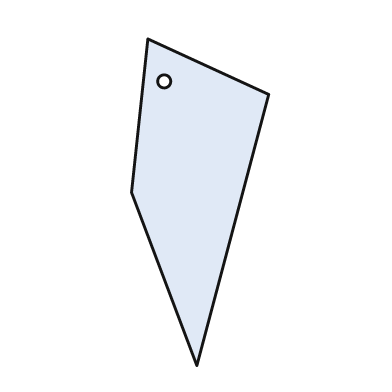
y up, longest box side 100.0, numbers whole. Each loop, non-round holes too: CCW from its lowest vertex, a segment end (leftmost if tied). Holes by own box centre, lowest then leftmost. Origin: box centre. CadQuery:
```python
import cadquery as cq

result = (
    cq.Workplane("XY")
    .moveTo(-1.0, -50.0)
    .lineTo(21.0, 33.0)
    .lineTo(-16.0, 50.0)
    .lineTo(-21.0, 3.0)
    .close()
    .moveTo(-11.0, 37.0)
    .circle(2.0)
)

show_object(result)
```